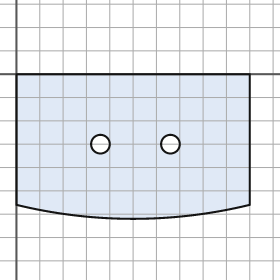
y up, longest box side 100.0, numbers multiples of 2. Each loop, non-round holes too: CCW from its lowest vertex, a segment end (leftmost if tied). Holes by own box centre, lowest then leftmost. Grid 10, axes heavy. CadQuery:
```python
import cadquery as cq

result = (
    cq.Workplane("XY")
    .moveTo(0.0, -56.0)
    .threePointArc((50.0, -62.0), (100.0, -56.0))
    .lineTo(100.0, 0.0)
    .lineTo(0.0, 0.0)
    .close()
    .moveTo(36.0, -30.0)
    .circle(4.0)
    .moveTo(66.0, -30.0)
    .circle(4.0)
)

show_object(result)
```